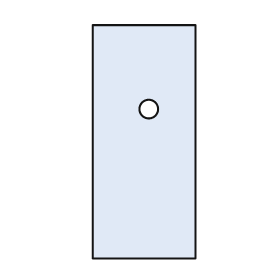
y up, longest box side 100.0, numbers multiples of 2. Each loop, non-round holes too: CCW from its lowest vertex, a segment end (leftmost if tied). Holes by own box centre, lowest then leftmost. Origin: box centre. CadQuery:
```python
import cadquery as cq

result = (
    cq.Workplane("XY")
    .moveTo(-22.0, -50.0)
    .lineTo(22.0, -50.0)
    .lineTo(22.0, 50.0)
    .lineTo(-22.0, 50.0)
    .close()
    .moveTo(2.0, 14.0)
    .circle(4.0)
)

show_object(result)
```